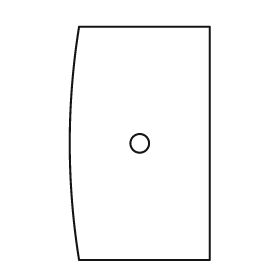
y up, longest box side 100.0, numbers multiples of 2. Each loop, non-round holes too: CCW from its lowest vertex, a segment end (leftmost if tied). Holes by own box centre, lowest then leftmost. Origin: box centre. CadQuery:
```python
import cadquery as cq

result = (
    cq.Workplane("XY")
    .moveTo(-26.0, -50.0)
    .lineTo(30.0, -50.0)
    .lineTo(30.0, 50.0)
    .lineTo(-26.0, 50.0)
    .threePointArc((-30.0, 0.0), (-26.0, -50.0))
    .close()
    .moveTo(0.0, 0.0)
    .circle(4.0)
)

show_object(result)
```